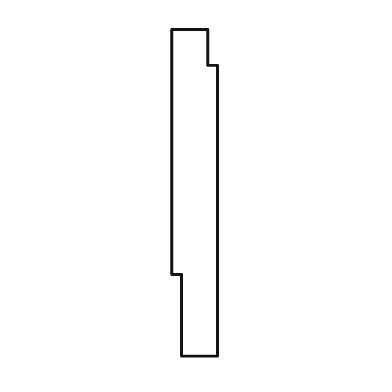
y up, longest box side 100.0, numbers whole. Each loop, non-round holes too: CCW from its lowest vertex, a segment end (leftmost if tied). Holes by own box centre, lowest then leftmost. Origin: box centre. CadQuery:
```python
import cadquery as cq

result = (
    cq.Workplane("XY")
    .moveTo(-4.0, -50.0)
    .lineTo(7.0, -50.0)
    .lineTo(7.0, 39.0)
    .lineTo(4.0, 39.0)
    .lineTo(4.0, 50.0)
    .lineTo(-7.0, 50.0)
    .lineTo(-7.0, -25.0)
    .lineTo(-4.0, -25.0)
    .close()
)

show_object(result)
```